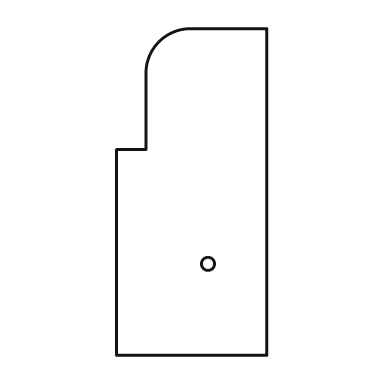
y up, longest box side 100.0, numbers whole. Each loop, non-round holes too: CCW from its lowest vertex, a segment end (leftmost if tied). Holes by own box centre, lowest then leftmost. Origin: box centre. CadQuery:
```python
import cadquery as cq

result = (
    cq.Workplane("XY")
    .moveTo(-23.0, -50.0)
    .lineTo(23.0, -50.0)
    .lineTo(23.0, 50.0)
    .lineTo(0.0, 50.0)
    .threePointArc((-10.0, 46.0), (-14.0, 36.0))
    .lineTo(-14.0, 13.0)
    .lineTo(-23.0, 13.0)
    .close()
    .moveTo(5.0, -22.0)
    .circle(2.0)
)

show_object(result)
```